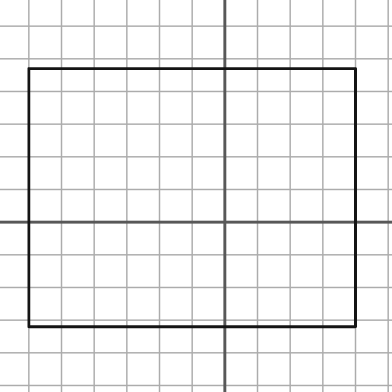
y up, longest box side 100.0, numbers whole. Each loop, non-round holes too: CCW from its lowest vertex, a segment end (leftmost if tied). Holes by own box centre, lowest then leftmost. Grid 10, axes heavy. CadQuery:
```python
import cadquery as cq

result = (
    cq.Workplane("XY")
    .moveTo(-60.0, -32.0)
    .lineTo(40.0, -32.0)
    .lineTo(40.0, 47.0)
    .lineTo(-60.0, 47.0)
    .close()
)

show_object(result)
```